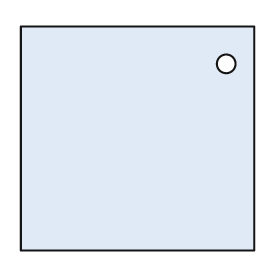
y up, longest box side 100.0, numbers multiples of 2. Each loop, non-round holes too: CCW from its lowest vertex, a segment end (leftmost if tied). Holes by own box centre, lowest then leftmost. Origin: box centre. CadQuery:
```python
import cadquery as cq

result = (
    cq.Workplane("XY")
    .moveTo(-50.0, -48.0)
    .lineTo(50.0, -48.0)
    .lineTo(50.0, 48.0)
    .lineTo(-50.0, 48.0)
    .close()
    .moveTo(38.0, 32.0)
    .circle(4.0)
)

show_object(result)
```